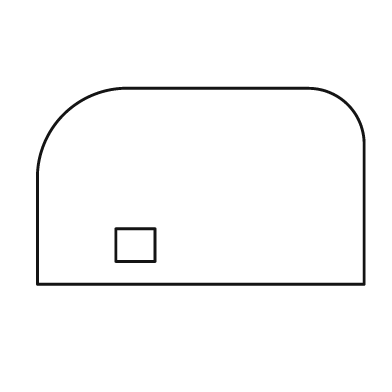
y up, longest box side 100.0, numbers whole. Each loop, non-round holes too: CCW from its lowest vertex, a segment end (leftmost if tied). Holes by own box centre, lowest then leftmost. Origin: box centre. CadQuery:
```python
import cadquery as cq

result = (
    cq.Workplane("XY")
    .moveTo(-50.0, -30.0)
    .lineTo(50.0, -30.0)
    .lineTo(50.0, 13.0)
    .threePointArc((45.0, 25.0), (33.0, 30.0))
    .lineTo(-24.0, 30.0)
    .threePointArc((-42.0, 22.0), (-50.0, 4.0))
    .close()
    .moveTo(-26.0, -23.0)
    .lineTo(-14.0, -23.0)
    .lineTo(-14.0, -13.0)
    .lineTo(-26.0, -13.0)
    .close()
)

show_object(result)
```